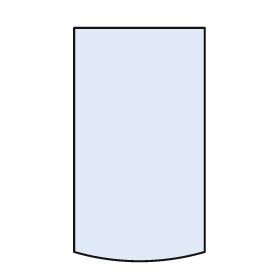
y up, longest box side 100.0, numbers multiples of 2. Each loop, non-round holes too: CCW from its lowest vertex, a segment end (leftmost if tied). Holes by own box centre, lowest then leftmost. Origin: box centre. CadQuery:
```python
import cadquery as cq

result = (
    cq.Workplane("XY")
    .moveTo(-28.0, -46.0)
    .threePointArc((0.0, -50.0), (28.0, -46.0))
    .lineTo(28.0, 50.0)
    .lineTo(-28.0, 50.0)
    .close()
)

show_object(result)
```